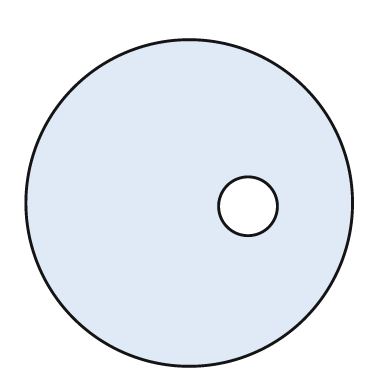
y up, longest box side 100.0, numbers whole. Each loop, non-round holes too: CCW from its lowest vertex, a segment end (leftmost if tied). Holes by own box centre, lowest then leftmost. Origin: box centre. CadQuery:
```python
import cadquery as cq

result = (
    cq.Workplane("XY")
    .moveTo(0.0, 0.0)
    .circle(50.0)
    .moveTo(18.0, -1.0)
    .circle(9.0)
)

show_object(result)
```